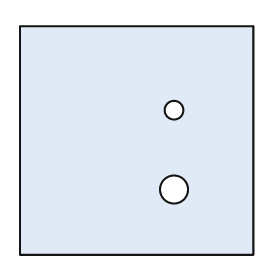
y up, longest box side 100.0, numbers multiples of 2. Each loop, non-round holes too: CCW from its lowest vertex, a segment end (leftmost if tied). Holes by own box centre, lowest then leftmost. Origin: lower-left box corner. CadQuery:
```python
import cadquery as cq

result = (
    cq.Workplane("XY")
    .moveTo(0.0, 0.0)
    .lineTo(100.0, 0.0)
    .lineTo(100.0, 98.0)
    .lineTo(0.0, 98.0)
    .close()
    .moveTo(66.0, 28.0)
    .circle(6.0)
    .moveTo(66.0, 62.0)
    .circle(4.0)
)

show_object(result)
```